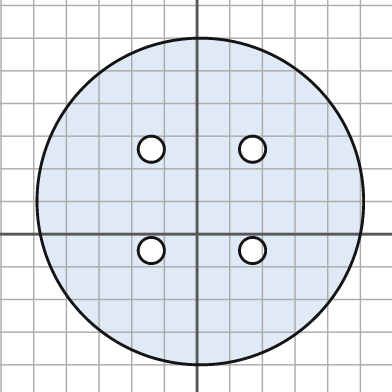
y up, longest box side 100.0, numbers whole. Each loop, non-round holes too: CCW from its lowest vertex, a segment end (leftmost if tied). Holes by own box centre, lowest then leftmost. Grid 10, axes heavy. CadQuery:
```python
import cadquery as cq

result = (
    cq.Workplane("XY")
    .moveTo(1.0, 10.0)
    .circle(50.0)
    .moveTo(-14.0, -5.0)
    .circle(4.0)
    .moveTo(17.0, -5.0)
    .circle(4.0)
    .moveTo(-14.0, 26.0)
    .circle(4.0)
    .moveTo(17.0, 26.0)
    .circle(4.0)
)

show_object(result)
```